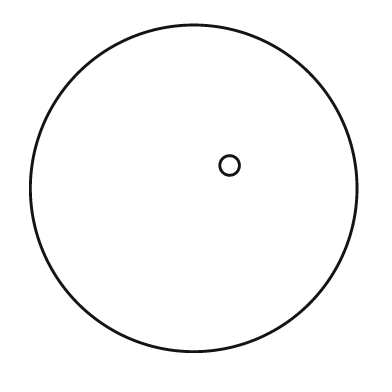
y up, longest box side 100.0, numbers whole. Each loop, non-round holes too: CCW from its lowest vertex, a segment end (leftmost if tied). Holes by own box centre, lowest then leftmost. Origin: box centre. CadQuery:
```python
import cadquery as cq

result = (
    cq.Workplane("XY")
    .moveTo(0.0, 0.0)
    .circle(50.0)
    .moveTo(11.0, 7.0)
    .circle(3.0)
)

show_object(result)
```